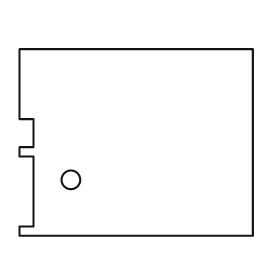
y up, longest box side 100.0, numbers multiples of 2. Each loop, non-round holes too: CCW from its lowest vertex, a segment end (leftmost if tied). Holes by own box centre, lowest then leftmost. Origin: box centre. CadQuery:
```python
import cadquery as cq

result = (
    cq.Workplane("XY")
    .moveTo(-50.0, -40.0)
    .lineTo(50.0, -40.0)
    .lineTo(50.0, 40.0)
    .lineTo(-50.0, 40.0)
    .lineTo(-50.0, 10.0)
    .lineTo(-44.0, 10.0)
    .lineTo(-44.0, -2.0)
    .lineTo(-50.0, -2.0)
    .lineTo(-50.0, -6.0)
    .lineTo(-44.0, -6.0)
    .lineTo(-44.0, -36.0)
    .lineTo(-50.0, -36.0)
    .close()
    .moveTo(-28.0, -16.0)
    .circle(4.0)
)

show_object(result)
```